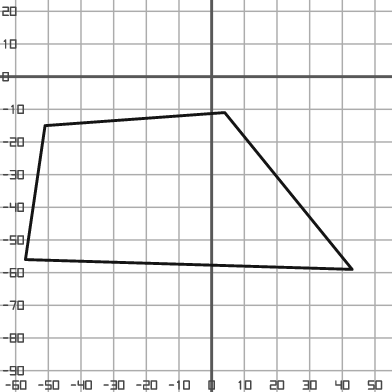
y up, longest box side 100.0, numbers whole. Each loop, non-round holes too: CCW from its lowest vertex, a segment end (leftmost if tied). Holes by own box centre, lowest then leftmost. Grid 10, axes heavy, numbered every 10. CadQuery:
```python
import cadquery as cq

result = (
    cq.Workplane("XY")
    .moveTo(43.0, -59.0)
    .lineTo(4.0, -11.0)
    .lineTo(-51.0, -15.0)
    .lineTo(-57.0, -56.0)
    .close()
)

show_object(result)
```